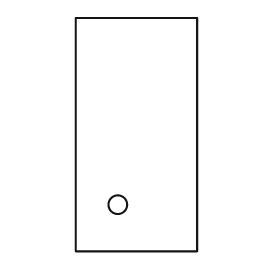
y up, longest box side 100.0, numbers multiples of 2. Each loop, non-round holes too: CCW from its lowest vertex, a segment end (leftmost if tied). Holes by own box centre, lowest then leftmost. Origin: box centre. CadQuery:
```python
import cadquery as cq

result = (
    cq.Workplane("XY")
    .moveTo(-26.0, -50.0)
    .lineTo(26.0, -50.0)
    .lineTo(26.0, 50.0)
    .lineTo(-26.0, 50.0)
    .close()
    .moveTo(-8.0, -30.0)
    .circle(4.0)
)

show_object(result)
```